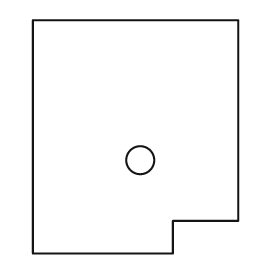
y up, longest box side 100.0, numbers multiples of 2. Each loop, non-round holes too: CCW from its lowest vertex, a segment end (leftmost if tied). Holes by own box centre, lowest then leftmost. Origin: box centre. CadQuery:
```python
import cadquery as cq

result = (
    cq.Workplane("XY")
    .moveTo(-44.0, -50.0)
    .lineTo(16.0, -50.0)
    .lineTo(16.0, -36.0)
    .lineTo(44.0, -36.0)
    .lineTo(44.0, 50.0)
    .lineTo(-44.0, 50.0)
    .close()
    .moveTo(2.0, -10.0)
    .circle(6.0)
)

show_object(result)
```